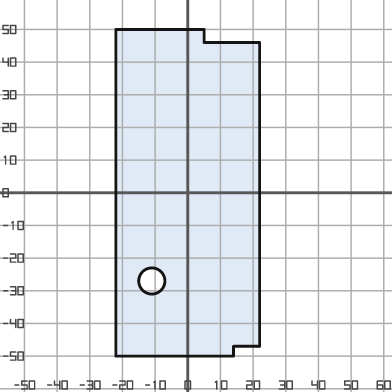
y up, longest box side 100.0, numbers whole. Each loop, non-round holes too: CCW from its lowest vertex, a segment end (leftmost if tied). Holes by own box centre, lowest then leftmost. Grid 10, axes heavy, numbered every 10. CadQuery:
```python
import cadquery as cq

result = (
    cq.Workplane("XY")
    .moveTo(-22.0, -50.0)
    .lineTo(14.0, -50.0)
    .lineTo(14.0, -47.0)
    .lineTo(22.0, -47.0)
    .lineTo(22.0, 46.0)
    .lineTo(5.0, 46.0)
    .lineTo(5.0, 50.0)
    .lineTo(-22.0, 50.0)
    .close()
    .moveTo(-11.0, -27.0)
    .circle(4.0)
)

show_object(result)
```